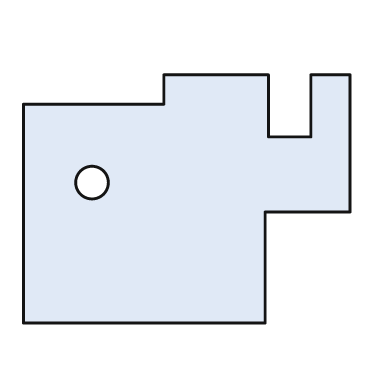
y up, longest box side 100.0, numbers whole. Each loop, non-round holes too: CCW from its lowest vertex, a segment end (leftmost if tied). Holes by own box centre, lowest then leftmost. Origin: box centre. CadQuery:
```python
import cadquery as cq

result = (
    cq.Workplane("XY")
    .moveTo(-50.0, -38.0)
    .lineTo(24.0, -38.0)
    .lineTo(24.0, -4.0)
    .lineTo(50.0, -4.0)
    .lineTo(50.0, 38.0)
    .lineTo(38.0, 38.0)
    .lineTo(38.0, 19.0)
    .lineTo(25.0, 19.0)
    .lineTo(25.0, 38.0)
    .lineTo(-7.0, 38.0)
    .lineTo(-7.0, 29.0)
    .lineTo(-50.0, 29.0)
    .close()
    .moveTo(-29.0, 5.0)
    .circle(5.0)
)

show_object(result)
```